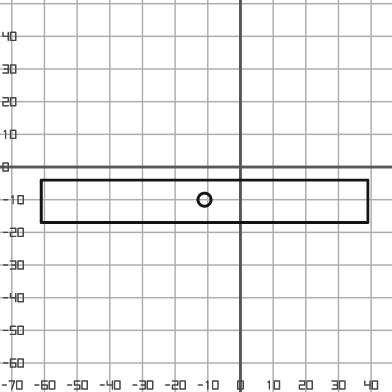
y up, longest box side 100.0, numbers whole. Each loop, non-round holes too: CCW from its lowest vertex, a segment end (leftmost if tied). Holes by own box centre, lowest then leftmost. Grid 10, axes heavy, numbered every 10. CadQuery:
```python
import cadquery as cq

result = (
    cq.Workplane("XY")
    .moveTo(-61.0, -17.0)
    .lineTo(39.0, -17.0)
    .lineTo(39.0, -4.0)
    .lineTo(-61.0, -4.0)
    .close()
    .moveTo(-11.0, -10.0)
    .circle(2.0)
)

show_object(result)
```